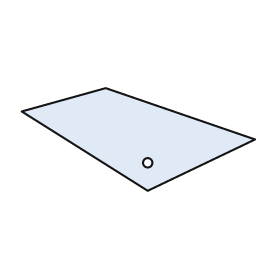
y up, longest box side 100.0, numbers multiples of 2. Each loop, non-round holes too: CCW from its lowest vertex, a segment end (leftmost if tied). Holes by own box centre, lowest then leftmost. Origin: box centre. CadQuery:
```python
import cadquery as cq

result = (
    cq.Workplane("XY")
    .moveTo(4.0, -22.0)
    .lineTo(50.0, 0.0)
    .lineTo(-14.0, 22.0)
    .lineTo(-50.0, 12.0)
    .close()
    .moveTo(4.0, -10.0)
    .circle(2.0)
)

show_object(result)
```